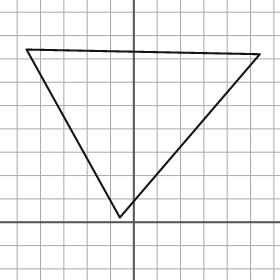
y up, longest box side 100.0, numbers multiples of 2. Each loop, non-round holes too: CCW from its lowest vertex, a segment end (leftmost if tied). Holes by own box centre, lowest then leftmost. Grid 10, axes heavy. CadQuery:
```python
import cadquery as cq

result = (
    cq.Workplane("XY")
    .moveTo(-6.0, 2.0)
    .lineTo(54.0, 72.0)
    .lineTo(-46.0, 74.0)
    .close()
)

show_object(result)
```